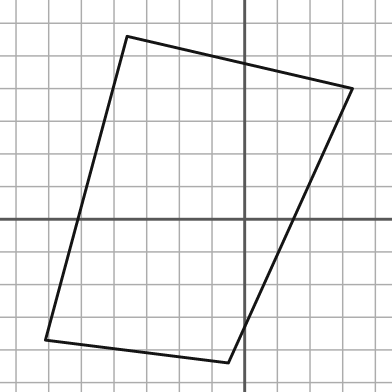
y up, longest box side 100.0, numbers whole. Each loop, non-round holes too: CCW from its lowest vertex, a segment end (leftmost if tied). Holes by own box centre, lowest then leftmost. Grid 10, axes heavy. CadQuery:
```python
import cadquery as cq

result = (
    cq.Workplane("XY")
    .moveTo(-5.0, -44.0)
    .lineTo(33.0, 40.0)
    .lineTo(-36.0, 56.0)
    .lineTo(-61.0, -37.0)
    .close()
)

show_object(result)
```